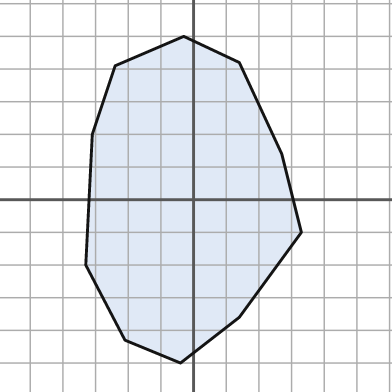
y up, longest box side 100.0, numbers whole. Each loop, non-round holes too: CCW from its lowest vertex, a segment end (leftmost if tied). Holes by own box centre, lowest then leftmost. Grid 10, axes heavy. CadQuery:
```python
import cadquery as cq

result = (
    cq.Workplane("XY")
    .moveTo(-4.0, -50.0)
    .lineTo(14.0, -36.0)
    .lineTo(33.0, -10.0)
    .lineTo(27.0, 14.0)
    .lineTo(14.0, 42.0)
    .lineTo(-3.0, 50.0)
    .lineTo(-24.0, 41.0)
    .lineTo(-31.0, 20.0)
    .lineTo(-33.0, -20.0)
    .lineTo(-21.0, -43.0)
    .close()
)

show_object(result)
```